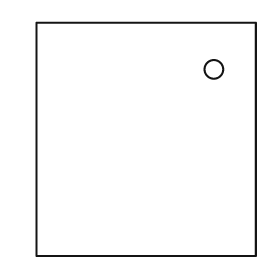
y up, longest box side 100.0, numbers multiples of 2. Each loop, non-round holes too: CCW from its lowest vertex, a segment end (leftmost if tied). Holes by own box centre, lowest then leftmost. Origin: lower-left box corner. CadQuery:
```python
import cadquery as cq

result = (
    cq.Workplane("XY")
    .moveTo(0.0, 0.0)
    .lineTo(94.0, 0.0)
    .lineTo(94.0, 100.0)
    .lineTo(0.0, 100.0)
    .close()
    .moveTo(76.0, 80.0)
    .circle(4.0)
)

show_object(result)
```